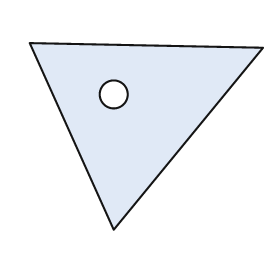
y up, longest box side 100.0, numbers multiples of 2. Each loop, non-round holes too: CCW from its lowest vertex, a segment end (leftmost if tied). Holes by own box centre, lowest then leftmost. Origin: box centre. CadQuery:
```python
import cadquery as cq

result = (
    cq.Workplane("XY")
    .moveTo(-14.0, -40.0)
    .lineTo(50.0, 38.0)
    .lineTo(-50.0, 40.0)
    .close()
    .moveTo(-14.0, 18.0)
    .circle(6.0)
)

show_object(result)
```